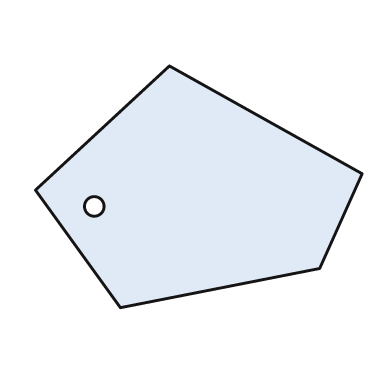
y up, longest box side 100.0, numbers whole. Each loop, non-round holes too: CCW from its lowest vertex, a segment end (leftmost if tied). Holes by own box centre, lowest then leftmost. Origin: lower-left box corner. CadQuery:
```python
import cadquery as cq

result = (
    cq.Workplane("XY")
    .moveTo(26.0, 0.0)
    .lineTo(87.0, 12.0)
    .lineTo(100.0, 41.0)
    .lineTo(41.0, 74.0)
    .lineTo(0.0, 36.0)
    .close()
    .moveTo(18.0, 31.0)
    .circle(3.0)
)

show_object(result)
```